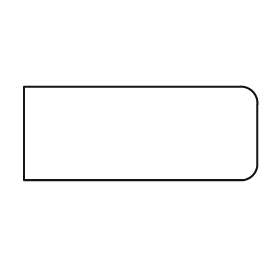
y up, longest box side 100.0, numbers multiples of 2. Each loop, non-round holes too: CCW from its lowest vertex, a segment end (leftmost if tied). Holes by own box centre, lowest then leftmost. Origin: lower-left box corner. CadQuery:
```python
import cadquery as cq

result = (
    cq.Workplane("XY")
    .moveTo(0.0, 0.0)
    .lineTo(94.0, 0.0)
    .threePointArc((98.0, 2.0), (100.0, 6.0))
    .lineTo(100.0, 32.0)
    .threePointArc((98.0, 38.0), (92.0, 40.0))
    .lineTo(0.0, 40.0)
    .close()
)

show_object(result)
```